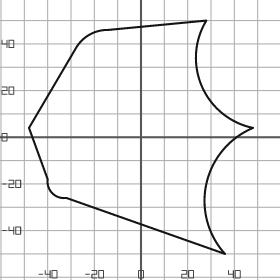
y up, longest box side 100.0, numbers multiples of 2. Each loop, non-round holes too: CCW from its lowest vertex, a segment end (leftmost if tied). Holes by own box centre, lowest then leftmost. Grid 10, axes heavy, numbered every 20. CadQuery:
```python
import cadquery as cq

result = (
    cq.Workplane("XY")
    .moveTo(36.0, -50.0)
    .threePointArc((28.0, -20.0), (48.0, 4.0))
    .threePointArc((26.0, 22.0), (28.0, 50.0))
    .lineTo(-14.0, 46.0)
    .threePointArc((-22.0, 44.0), (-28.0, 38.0))
    .lineTo(-48.0, 4.0)
    .lineTo(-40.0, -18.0)
    .threePointArc((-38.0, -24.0), (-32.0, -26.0))
    .close()
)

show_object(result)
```